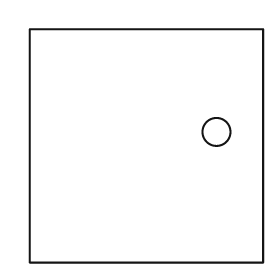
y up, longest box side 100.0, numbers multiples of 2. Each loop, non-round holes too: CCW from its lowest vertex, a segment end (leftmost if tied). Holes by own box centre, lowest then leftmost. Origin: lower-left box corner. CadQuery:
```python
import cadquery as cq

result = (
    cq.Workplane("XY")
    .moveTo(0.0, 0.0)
    .lineTo(100.0, 0.0)
    .lineTo(100.0, 100.0)
    .lineTo(0.0, 100.0)
    .close()
    .moveTo(80.0, 56.0)
    .circle(6.0)
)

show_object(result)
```